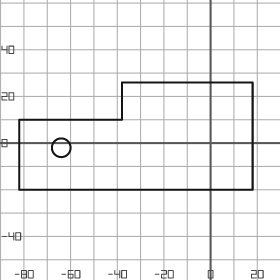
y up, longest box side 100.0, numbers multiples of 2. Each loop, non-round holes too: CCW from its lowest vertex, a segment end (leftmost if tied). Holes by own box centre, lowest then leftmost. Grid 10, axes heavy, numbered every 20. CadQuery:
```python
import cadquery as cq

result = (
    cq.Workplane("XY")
    .moveTo(-82.0, -20.0)
    .lineTo(18.0, -20.0)
    .lineTo(18.0, 26.0)
    .lineTo(-38.0, 26.0)
    .lineTo(-38.0, 10.0)
    .lineTo(-82.0, 10.0)
    .close()
    .moveTo(-64.0, -2.0)
    .circle(4.0)
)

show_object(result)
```